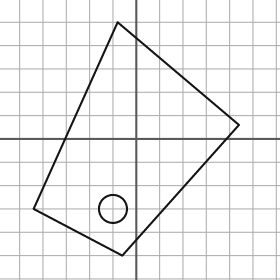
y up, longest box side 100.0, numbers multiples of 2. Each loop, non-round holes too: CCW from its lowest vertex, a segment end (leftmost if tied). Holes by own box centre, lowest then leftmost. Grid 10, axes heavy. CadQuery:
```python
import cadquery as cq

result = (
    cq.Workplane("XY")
    .moveTo(-6.0, -50.0)
    .lineTo(44.0, 6.0)
    .lineTo(-8.0, 50.0)
    .lineTo(-44.0, -30.0)
    .close()
    .moveTo(-10.0, -30.0)
    .circle(6.0)
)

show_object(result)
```